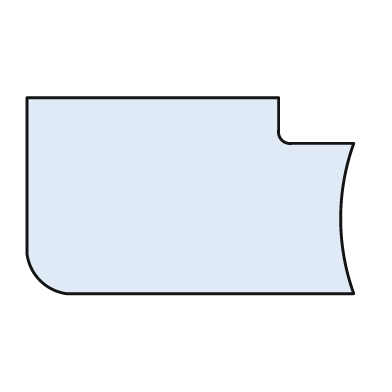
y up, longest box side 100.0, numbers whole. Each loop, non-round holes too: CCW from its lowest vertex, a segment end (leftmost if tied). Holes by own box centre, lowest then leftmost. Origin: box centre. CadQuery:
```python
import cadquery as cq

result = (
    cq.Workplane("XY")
    .moveTo(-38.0, -30.0)
    .lineTo(50.0, -30.0)
    .threePointArc((46.0, -7.0), (50.0, 16.0))
    .lineTo(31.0, 16.0)
    .threePointArc((28.0, 17.0), (27.0, 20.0))
    .lineTo(27.0, 30.0)
    .lineTo(-50.0, 30.0)
    .lineTo(-50.0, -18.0)
    .threePointArc((-46.0, -26.0), (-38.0, -30.0))
    .close()
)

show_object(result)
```